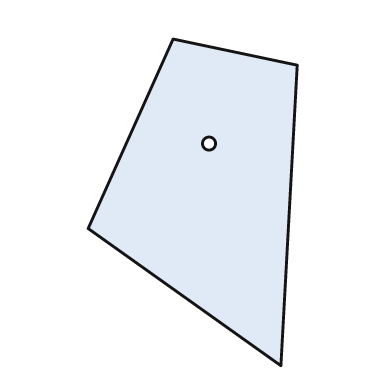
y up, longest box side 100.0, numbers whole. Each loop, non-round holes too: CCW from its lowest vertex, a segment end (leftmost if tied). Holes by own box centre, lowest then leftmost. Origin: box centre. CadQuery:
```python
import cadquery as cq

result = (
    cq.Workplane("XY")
    .moveTo(27.0, -50.0)
    .lineTo(32.0, 42.0)
    .lineTo(-6.0, 50.0)
    .lineTo(-32.0, -8.0)
    .close()
    .moveTo(5.0, 18.0)
    .circle(2.0)
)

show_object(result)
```